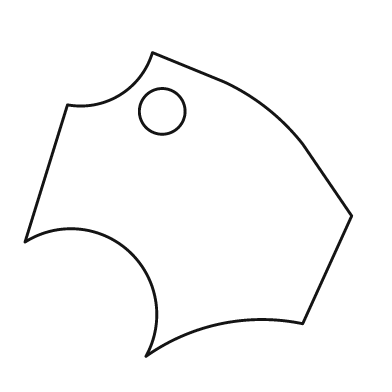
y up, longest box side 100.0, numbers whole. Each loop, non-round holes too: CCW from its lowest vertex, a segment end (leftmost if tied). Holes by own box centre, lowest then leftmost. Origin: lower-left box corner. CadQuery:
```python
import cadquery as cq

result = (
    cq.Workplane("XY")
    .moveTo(37.0, 0.0)
    .threePointArc((60.0, 10.0), (85.0, 10.0))
    .lineTo(100.0, 43.0)
    .lineTo(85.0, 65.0)
    .threePointArc((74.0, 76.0), (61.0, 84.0))
    .lineTo(39.0, 93.0)
    .threePointArc((29.0, 80.0), (13.0, 77.0))
    .lineTo(0.0, 35.0)
    .threePointArc((32.0, 32.0), (37.0, 0.0))
    .close()
    .moveTo(42.0, 75.0)
    .circle(7.0)
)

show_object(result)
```